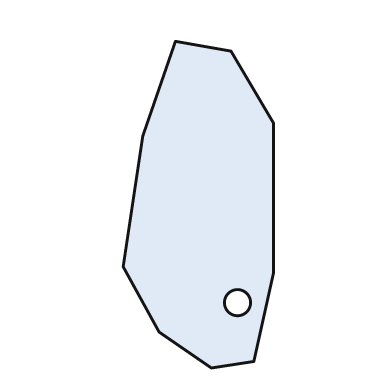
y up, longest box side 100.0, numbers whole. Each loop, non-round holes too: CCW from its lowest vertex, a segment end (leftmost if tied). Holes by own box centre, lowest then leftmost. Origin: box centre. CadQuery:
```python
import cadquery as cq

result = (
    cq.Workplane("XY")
    .moveTo(4.0, -50.0)
    .lineTo(17.0, -48.0)
    .lineTo(23.0, -21.0)
    .lineTo(23.0, 25.0)
    .lineTo(10.0, 47.0)
    .lineTo(-7.0, 50.0)
    .lineTo(-17.0, 21.0)
    .lineTo(-23.0, -19.0)
    .lineTo(-12.0, -39.0)
    .close()
    .moveTo(12.0, -30.0)
    .circle(4.0)
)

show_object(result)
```